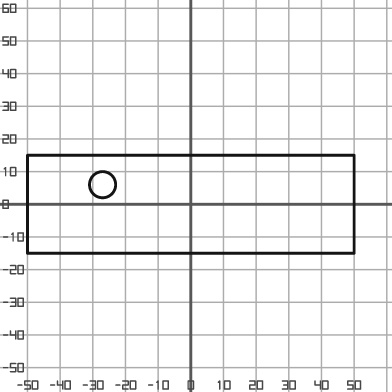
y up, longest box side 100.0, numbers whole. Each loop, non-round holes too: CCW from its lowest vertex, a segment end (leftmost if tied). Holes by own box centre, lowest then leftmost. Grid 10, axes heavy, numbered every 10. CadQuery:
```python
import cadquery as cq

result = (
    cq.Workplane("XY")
    .moveTo(-50.0, -15.0)
    .lineTo(50.0, -15.0)
    .lineTo(50.0, 15.0)
    .lineTo(-50.0, 15.0)
    .close()
    .moveTo(-27.0, 6.0)
    .circle(4.0)
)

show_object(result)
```